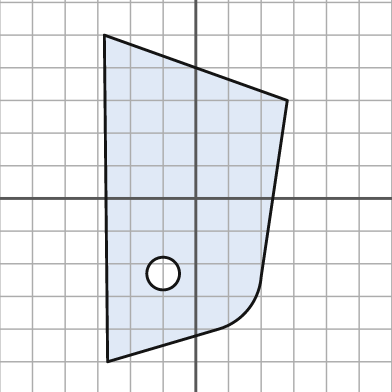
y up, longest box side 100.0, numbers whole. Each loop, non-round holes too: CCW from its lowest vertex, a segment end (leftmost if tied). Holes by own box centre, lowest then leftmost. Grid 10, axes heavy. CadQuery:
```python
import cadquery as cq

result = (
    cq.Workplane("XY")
    .moveTo(-27.0, -50.0)
    .lineTo(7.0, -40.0)
    .threePointArc((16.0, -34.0), (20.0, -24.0))
    .lineTo(28.0, 30.0)
    .lineTo(-28.0, 50.0)
    .close()
    .moveTo(-10.0, -23.0)
    .circle(5.0)
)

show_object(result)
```